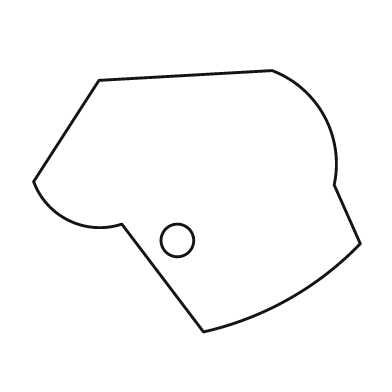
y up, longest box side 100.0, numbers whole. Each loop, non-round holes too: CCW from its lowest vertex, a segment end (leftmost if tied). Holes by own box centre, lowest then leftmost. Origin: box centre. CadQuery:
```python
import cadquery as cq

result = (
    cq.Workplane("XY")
    .moveTo(2.0, -40.0)
    .threePointArc((28.0, -30.0), (50.0, -13.0))
    .lineTo(42.0, 5.0)
    .threePointArc((39.0, 26.0), (23.0, 40.0))
    .lineTo(-30.0, 37.0)
    .lineTo(-50.0, 6.0)
    .threePointArc((-39.0, -6.0), (-23.0, -7.0))
    .close()
    .moveTo(-6.0, -12.0)
    .circle(5.0)
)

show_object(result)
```